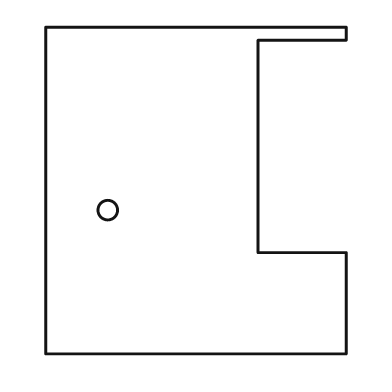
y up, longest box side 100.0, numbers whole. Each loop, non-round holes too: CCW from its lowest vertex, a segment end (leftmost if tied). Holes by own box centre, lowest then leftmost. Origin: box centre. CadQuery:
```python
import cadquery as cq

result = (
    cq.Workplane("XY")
    .moveTo(-46.0, -50.0)
    .lineTo(46.0, -50.0)
    .lineTo(46.0, -19.0)
    .lineTo(19.0, -19.0)
    .lineTo(19.0, 46.0)
    .lineTo(46.0, 46.0)
    .lineTo(46.0, 50.0)
    .lineTo(-46.0, 50.0)
    .close()
    .moveTo(-27.0, -6.0)
    .circle(3.0)
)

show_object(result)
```